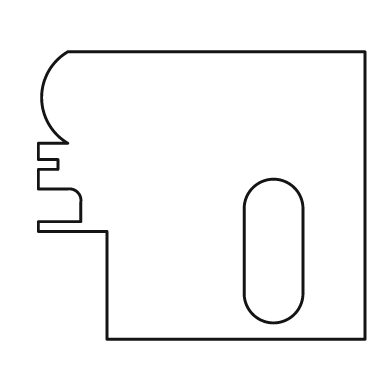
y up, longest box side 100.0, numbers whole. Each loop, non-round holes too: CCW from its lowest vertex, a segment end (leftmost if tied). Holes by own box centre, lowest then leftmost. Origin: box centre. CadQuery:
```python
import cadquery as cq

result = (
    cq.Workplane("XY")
    .moveTo(-29.0, -44.0)
    .lineTo(50.0, -44.0)
    .lineTo(50.0, 44.0)
    .lineTo(-41.0, 44.0)
    .threePointArc((-49.0, 30.0), (-41.0, 16.0))
    .lineTo(-50.0, 16.0)
    .lineTo(-50.0, 11.0)
    .lineTo(-44.0, 11.0)
    .lineTo(-44.0, 8.0)
    .lineTo(-50.0, 8.0)
    .lineTo(-50.0, 2.0)
    .lineTo(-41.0, 2.0)
    .threePointArc((-38.0, 1.0), (-37.0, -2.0))
    .lineTo(-37.0, -8.0)
    .lineTo(-50.0, -8.0)
    .lineTo(-50.0, -11.0)
    .lineTo(-29.0, -11.0)
    .close()
    .moveTo(13.0, -30.0)
    .threePointArc((22.0, -39.0), (31.0, -30.0))
    .lineTo(31.0, -4.0)
    .threePointArc((22.0, 5.0), (13.0, -4.0))
    .close()
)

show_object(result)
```